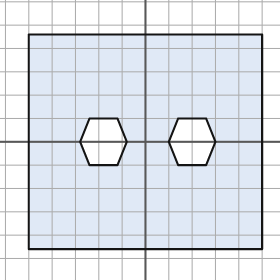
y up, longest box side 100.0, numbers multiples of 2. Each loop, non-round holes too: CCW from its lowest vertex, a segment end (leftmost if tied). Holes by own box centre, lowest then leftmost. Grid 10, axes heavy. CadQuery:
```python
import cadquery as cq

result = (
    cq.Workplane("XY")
    .moveTo(-50.0, -46.0)
    .lineTo(50.0, -46.0)
    .lineTo(50.0, 46.0)
    .lineTo(-50.0, 46.0)
    .close()
    .moveTo(-24.0, -10.0)
    .lineTo(-12.0, -10.0)
    .lineTo(-8.0, 0.0)
    .lineTo(-12.0, 10.0)
    .lineTo(-24.0, 10.0)
    .lineTo(-28.0, 0.0)
    .close()
    .moveTo(14.0, -10.0)
    .lineTo(26.0, -10.0)
    .lineTo(30.0, 0.0)
    .lineTo(26.0, 10.0)
    .lineTo(14.0, 10.0)
    .lineTo(10.0, 0.0)
    .close()
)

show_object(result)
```